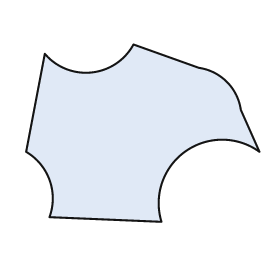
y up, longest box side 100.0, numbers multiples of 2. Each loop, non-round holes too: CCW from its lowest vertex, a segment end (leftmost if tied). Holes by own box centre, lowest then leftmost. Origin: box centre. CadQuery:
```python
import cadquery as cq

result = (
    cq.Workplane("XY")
    .moveTo(8.0, -38.0)
    .threePointArc((18.0, -8.0), (50.0, -8.0))
    .lineTo(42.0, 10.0)
    .threePointArc((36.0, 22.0), (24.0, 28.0))
    .lineTo(-4.0, 38.0)
    .threePointArc((-22.0, 26.0), (-42.0, 34.0))
    .lineTo(-50.0, -8.0)
    .threePointArc((-40.0, -20.0), (-40.0, -36.0))
    .close()
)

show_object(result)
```